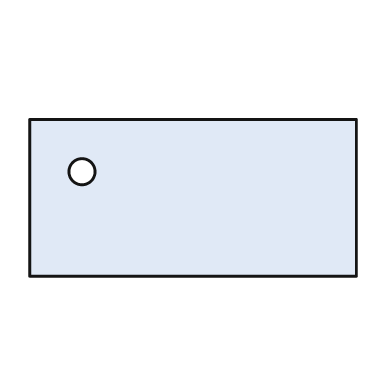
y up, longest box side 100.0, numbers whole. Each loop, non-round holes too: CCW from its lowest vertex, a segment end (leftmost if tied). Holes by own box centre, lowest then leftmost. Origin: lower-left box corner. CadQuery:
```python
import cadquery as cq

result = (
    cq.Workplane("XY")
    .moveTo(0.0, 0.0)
    .lineTo(100.0, 0.0)
    .lineTo(100.0, 48.0)
    .lineTo(0.0, 48.0)
    .close()
    .moveTo(16.0, 32.0)
    .circle(4.0)
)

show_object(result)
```